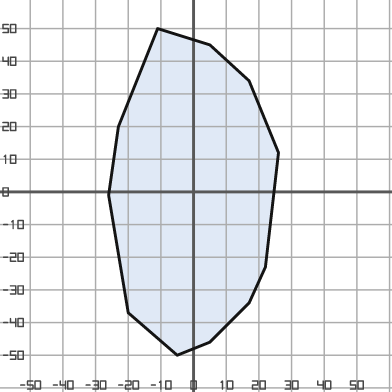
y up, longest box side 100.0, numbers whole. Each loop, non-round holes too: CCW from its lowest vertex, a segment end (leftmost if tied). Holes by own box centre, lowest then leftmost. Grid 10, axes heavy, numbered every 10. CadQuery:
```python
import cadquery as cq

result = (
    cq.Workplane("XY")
    .moveTo(-5.0, -50.0)
    .lineTo(5.0, -46.0)
    .lineTo(17.0, -34.0)
    .lineTo(22.0, -23.0)
    .lineTo(26.0, 12.0)
    .lineTo(17.0, 34.0)
    .lineTo(5.0, 45.0)
    .lineTo(-11.0, 50.0)
    .lineTo(-23.0, 20.0)
    .lineTo(-26.0, -1.0)
    .lineTo(-20.0, -37.0)
    .close()
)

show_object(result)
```